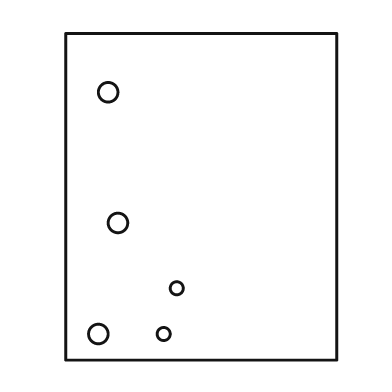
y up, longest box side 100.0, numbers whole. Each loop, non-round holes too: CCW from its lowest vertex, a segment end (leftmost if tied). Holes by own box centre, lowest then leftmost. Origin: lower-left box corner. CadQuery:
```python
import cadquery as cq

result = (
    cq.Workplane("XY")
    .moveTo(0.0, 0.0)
    .lineTo(83.0, 0.0)
    .lineTo(83.0, 100.0)
    .lineTo(0.0, 100.0)
    .close()
    .moveTo(10.0, 8.0)
    .circle(3.0)
    .moveTo(30.0, 8.0)
    .circle(2.0)
    .moveTo(34.0, 22.0)
    .circle(2.0)
    .moveTo(16.0, 42.0)
    .circle(3.0)
    .moveTo(13.0, 82.0)
    .circle(3.0)
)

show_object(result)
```